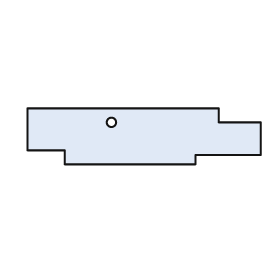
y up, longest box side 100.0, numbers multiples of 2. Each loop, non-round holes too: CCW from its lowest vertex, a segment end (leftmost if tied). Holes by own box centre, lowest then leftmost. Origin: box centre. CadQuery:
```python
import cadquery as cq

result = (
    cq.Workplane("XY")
    .moveTo(-34.0, -12.0)
    .lineTo(22.0, -12.0)
    .lineTo(22.0, -8.0)
    .lineTo(50.0, -8.0)
    .lineTo(50.0, 6.0)
    .lineTo(32.0, 6.0)
    .lineTo(32.0, 12.0)
    .lineTo(-50.0, 12.0)
    .lineTo(-50.0, -6.0)
    .lineTo(-34.0, -6.0)
    .close()
    .moveTo(-14.0, 6.0)
    .circle(2.0)
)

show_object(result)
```